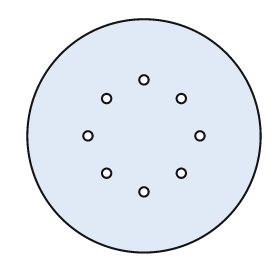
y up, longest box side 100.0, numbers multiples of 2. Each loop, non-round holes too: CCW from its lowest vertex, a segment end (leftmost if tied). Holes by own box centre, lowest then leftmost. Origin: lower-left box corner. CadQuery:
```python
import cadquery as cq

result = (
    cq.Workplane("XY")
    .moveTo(50.0, 50.0)
    .circle(50.0)
    .moveTo(50.0, 26.0)
    .circle(2.0)
    .moveTo(34.0, 34.0)
    .circle(2.0)
    .moveTo(66.0, 34.0)
    .circle(2.0)
    .moveTo(26.0, 50.0)
    .circle(2.0)
    .moveTo(74.0, 50.0)
    .circle(2.0)
    .moveTo(34.0, 66.0)
    .circle(2.0)
    .moveTo(66.0, 66.0)
    .circle(2.0)
    .moveTo(50.0, 74.0)
    .circle(2.0)
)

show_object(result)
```